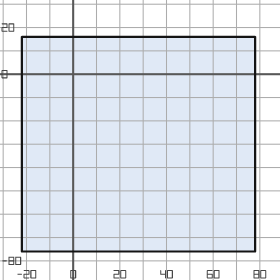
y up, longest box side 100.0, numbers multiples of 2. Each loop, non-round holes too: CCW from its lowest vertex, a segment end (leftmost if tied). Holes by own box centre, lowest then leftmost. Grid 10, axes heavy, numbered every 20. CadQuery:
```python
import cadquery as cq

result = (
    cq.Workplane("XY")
    .moveTo(-22.0, -76.0)
    .lineTo(78.0, -76.0)
    .lineTo(78.0, 16.0)
    .lineTo(-22.0, 16.0)
    .close()
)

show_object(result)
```